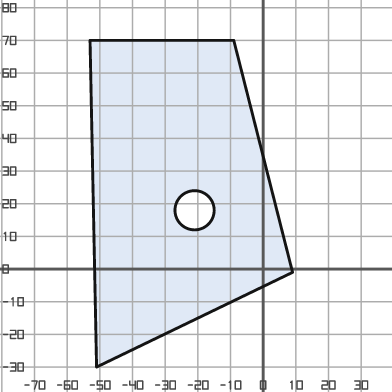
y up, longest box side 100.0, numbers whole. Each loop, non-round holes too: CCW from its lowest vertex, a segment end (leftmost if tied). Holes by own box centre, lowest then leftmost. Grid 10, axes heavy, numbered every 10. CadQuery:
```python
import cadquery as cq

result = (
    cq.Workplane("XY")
    .moveTo(-51.0, -30.0)
    .lineTo(9.0, -1.0)
    .lineTo(-9.0, 70.0)
    .lineTo(-53.0, 70.0)
    .close()
    .moveTo(-21.0, 18.0)
    .circle(6.0)
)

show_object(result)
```